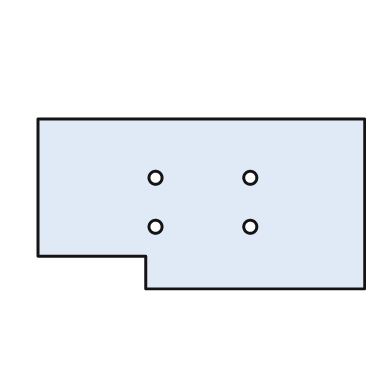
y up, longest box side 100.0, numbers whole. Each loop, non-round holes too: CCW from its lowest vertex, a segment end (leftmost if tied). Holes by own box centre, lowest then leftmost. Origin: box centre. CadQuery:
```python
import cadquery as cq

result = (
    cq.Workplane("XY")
    .moveTo(-17.0, -26.0)
    .lineTo(50.0, -26.0)
    .lineTo(50.0, 26.0)
    .lineTo(-50.0, 26.0)
    .lineTo(-50.0, -16.0)
    .lineTo(-17.0, -16.0)
    .close()
    .moveTo(-14.0, -7.0)
    .circle(2.0)
    .moveTo(15.0, -7.0)
    .circle(2.0)
    .moveTo(-14.0, 8.0)
    .circle(2.0)
    .moveTo(15.0, 8.0)
    .circle(2.0)
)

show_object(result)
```